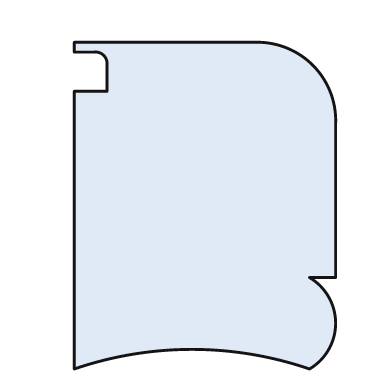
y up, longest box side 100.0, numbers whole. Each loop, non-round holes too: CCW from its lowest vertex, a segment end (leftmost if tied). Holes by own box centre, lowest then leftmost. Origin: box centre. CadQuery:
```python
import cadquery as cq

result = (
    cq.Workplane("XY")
    .moveTo(-40.0, -50.0)
    .threePointArc((-4.0, -44.0), (32.0, -50.0))
    .threePointArc((40.0, -36.0), (32.0, -22.0))
    .lineTo(40.0, -22.0)
    .lineTo(40.0, 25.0)
    .threePointArc((33.0, 43.0), (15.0, 50.0))
    .lineTo(-40.0, 50.0)
    .lineTo(-40.0, 47.0)
    .lineTo(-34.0, 47.0)
    .threePointArc((-31.0, 46.0), (-30.0, 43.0))
    .lineTo(-30.0, 35.0)
    .lineTo(-40.0, 35.0)
    .close()
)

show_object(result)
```